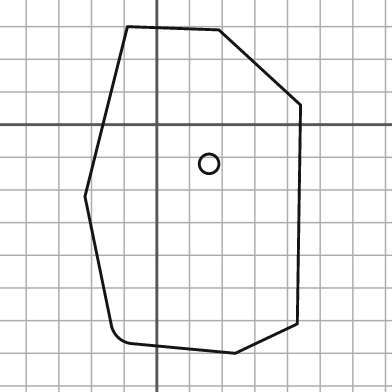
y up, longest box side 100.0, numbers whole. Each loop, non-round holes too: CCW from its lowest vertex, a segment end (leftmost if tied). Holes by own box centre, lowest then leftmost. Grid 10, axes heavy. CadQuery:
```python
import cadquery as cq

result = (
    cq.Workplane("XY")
    .moveTo(24.0, -70.0)
    .lineTo(43.0, -61.0)
    .lineTo(44.0, 6.0)
    .lineTo(19.0, 29.0)
    .lineTo(-9.0, 30.0)
    .lineTo(-22.0, -22.0)
    .lineTo(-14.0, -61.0)
    .threePointArc((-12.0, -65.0), (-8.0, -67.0))
    .close()
    .moveTo(16.0, -12.0)
    .circle(3.0)
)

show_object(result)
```